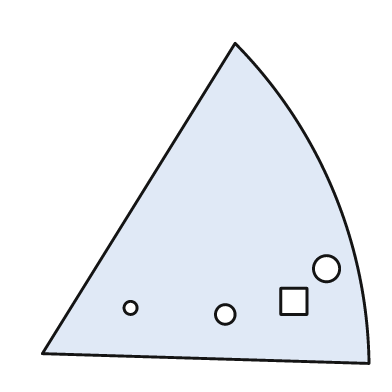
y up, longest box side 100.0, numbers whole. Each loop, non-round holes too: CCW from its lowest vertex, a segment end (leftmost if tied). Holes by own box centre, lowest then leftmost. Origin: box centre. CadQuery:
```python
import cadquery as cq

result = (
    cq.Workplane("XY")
    .moveTo(50.0, -49.0)
    .threePointArc((39.0, 4.0), (9.0, 49.0))
    .lineTo(-50.0, -46.0)
    .close()
    .moveTo(6.0, -34.0)
    .circle(3.0)
    .moveTo(-23.0, -32.0)
    .circle(2.0)
    .moveTo(23.0, -34.0)
    .lineTo(31.0, -34.0)
    .lineTo(31.0, -26.0)
    .lineTo(23.0, -26.0)
    .close()
    .moveTo(37.0, -20.0)
    .circle(4.0)
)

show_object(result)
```